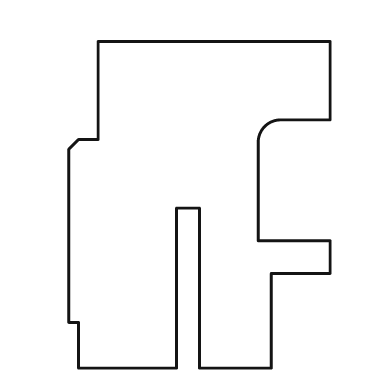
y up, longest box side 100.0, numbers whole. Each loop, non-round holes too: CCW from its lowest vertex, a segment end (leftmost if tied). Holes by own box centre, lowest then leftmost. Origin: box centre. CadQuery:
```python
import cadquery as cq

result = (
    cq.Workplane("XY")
    .moveTo(-37.0, -50.0)
    .lineTo(-7.0, -50.0)
    .lineTo(-7.0, -1.0)
    .lineTo(0.0, -1.0)
    .lineTo(0.0, -50.0)
    .lineTo(22.0, -50.0)
    .lineTo(22.0, -21.0)
    .lineTo(40.0, -21.0)
    .lineTo(40.0, -11.0)
    .lineTo(18.0, -11.0)
    .lineTo(18.0, 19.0)
    .threePointArc((20.0, 24.0), (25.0, 26.0))
    .lineTo(40.0, 26.0)
    .lineTo(40.0, 50.0)
    .lineTo(-31.0, 50.0)
    .lineTo(-31.0, 20.0)
    .lineTo(-37.0, 20.0)
    .lineTo(-40.0, 17.0)
    .lineTo(-40.0, -36.0)
    .lineTo(-37.0, -36.0)
    .close()
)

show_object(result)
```